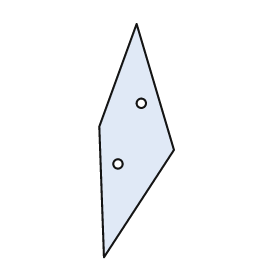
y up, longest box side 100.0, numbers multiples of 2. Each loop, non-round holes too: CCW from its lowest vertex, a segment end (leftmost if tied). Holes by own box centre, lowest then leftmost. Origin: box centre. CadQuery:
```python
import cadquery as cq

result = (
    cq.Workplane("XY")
    .moveTo(-14.0, -50.0)
    .lineTo(16.0, -4.0)
    .lineTo(0.0, 50.0)
    .lineTo(-16.0, 6.0)
    .close()
    .moveTo(-8.0, -10.0)
    .circle(2.0)
    .moveTo(2.0, 16.0)
    .circle(2.0)
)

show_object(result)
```